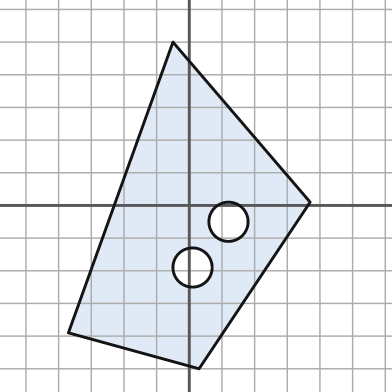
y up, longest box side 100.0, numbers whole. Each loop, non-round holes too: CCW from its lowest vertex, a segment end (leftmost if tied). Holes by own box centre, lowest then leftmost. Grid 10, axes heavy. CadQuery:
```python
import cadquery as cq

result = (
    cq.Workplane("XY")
    .moveTo(3.0, -50.0)
    .lineTo(37.0, 1.0)
    .lineTo(-5.0, 50.0)
    .lineTo(-37.0, -39.0)
    .close()
    .moveTo(1.0, -19.0)
    .circle(6.0)
    .moveTo(12.0, -5.0)
    .circle(6.0)
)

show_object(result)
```